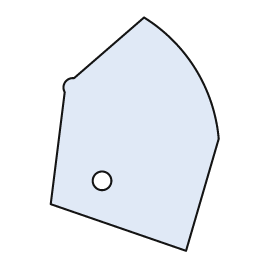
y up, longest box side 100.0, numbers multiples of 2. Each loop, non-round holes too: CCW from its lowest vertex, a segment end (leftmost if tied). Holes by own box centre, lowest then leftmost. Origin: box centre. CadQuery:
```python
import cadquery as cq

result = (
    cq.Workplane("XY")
    .moveTo(22.0, -50.0)
    .lineTo(36.0, -2.0)
    .threePointArc((26.0, 28.0), (4.0, 50.0))
    .lineTo(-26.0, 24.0)
    .threePointArc((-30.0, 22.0), (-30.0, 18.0))
    .lineTo(-36.0, -30.0)
    .close()
    .moveTo(-14.0, -20.0)
    .circle(4.0)
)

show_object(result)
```